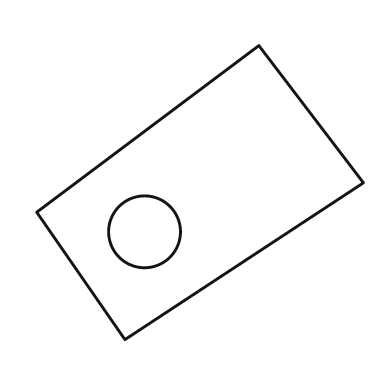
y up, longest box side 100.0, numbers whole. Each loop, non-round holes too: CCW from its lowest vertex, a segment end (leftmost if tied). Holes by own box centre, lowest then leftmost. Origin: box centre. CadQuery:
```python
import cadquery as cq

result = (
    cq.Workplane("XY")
    .moveTo(-23.0, -45.0)
    .lineTo(50.0, 3.0)
    .lineTo(18.0, 45.0)
    .lineTo(-50.0, -6.0)
    .close()
    .moveTo(-17.0, -12.0)
    .circle(11.0)
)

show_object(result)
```